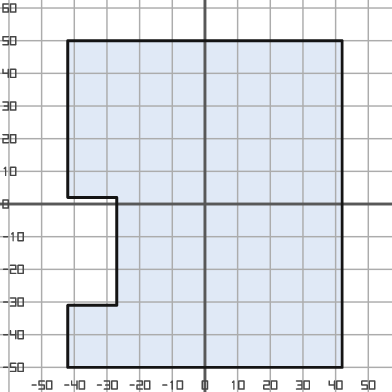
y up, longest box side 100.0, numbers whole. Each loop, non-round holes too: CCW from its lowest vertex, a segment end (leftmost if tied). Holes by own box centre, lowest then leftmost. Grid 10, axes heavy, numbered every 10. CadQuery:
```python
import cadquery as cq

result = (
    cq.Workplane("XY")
    .moveTo(-42.0, -50.0)
    .lineTo(42.0, -50.0)
    .lineTo(42.0, 50.0)
    .lineTo(-42.0, 50.0)
    .lineTo(-42.0, 2.0)
    .lineTo(-27.0, 2.0)
    .lineTo(-27.0, -31.0)
    .lineTo(-42.0, -31.0)
    .close()
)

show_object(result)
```